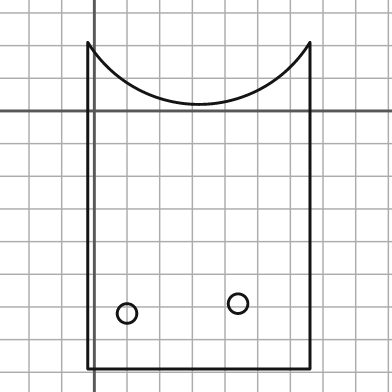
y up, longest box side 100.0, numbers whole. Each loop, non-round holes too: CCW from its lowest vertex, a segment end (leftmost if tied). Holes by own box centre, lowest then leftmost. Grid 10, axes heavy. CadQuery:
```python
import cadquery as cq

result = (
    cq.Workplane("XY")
    .moveTo(-2.0, -79.0)
    .lineTo(66.0, -79.0)
    .lineTo(66.0, 21.0)
    .threePointArc((32.0, 2.0), (-2.0, 21.0))
    .close()
    .moveTo(10.0, -62.0)
    .circle(3.0)
    .moveTo(44.0, -59.0)
    .circle(3.0)
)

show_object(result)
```